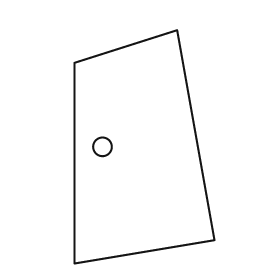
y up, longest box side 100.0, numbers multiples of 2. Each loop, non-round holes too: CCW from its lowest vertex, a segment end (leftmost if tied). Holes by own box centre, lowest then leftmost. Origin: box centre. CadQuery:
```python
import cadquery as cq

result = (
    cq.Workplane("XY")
    .moveTo(-30.0, -50.0)
    .lineTo(30.0, -40.0)
    .lineTo(14.0, 50.0)
    .lineTo(-30.0, 36.0)
    .close()
    .moveTo(-18.0, 0.0)
    .circle(4.0)
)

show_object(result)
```